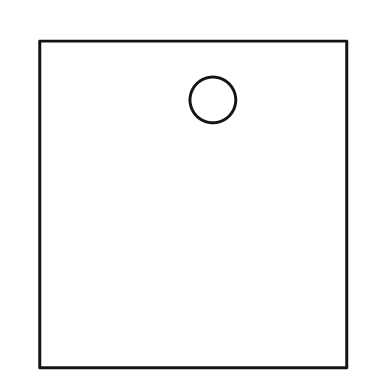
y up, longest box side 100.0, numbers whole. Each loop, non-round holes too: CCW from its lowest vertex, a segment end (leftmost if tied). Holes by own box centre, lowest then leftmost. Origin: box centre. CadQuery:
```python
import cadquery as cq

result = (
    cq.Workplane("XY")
    .moveTo(-47.0, -50.0)
    .lineTo(47.0, -50.0)
    .lineTo(47.0, 50.0)
    .lineTo(-47.0, 50.0)
    .close()
    .moveTo(6.0, 32.0)
    .circle(7.0)
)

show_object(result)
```